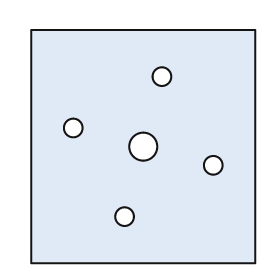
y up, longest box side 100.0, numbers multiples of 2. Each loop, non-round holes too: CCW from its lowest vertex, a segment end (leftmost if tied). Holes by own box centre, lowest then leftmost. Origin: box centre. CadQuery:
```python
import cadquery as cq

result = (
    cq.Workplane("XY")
    .moveTo(-48.0, -50.0)
    .lineTo(48.0, -50.0)
    .lineTo(48.0, 50.0)
    .lineTo(-48.0, 50.0)
    .close()
    .moveTo(-8.0, -30.0)
    .circle(4.0)
    .moveTo(30.0, -8.0)
    .circle(4.0)
    .moveTo(0.0, 0.0)
    .circle(6.0)
    .moveTo(-30.0, 8.0)
    .circle(4.0)
    .moveTo(8.0, 30.0)
    .circle(4.0)
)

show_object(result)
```